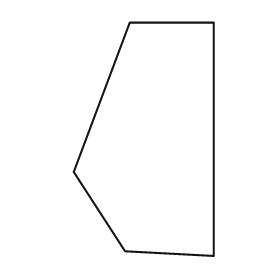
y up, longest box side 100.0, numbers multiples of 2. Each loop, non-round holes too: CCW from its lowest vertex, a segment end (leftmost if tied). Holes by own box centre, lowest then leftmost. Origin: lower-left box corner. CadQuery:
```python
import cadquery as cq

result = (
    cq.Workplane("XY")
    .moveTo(60.0, 0.0)
    .lineTo(60.0, 100.0)
    .lineTo(24.0, 100.0)
    .lineTo(0.0, 36.0)
    .lineTo(22.0, 2.0)
    .close()
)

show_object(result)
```